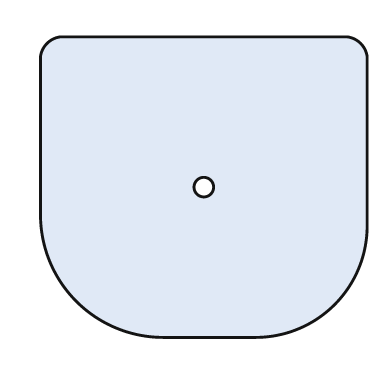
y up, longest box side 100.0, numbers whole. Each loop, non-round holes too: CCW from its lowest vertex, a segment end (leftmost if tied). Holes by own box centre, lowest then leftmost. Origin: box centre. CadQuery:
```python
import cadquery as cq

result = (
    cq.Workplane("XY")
    .moveTo(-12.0, -46.0)
    .lineTo(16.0, -46.0)
    .threePointArc((40.0, -36.0), (50.0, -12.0))
    .lineTo(50.0, 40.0)
    .threePointArc((48.0, 44.0), (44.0, 46.0))
    .lineTo(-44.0, 46.0)
    .threePointArc((-48.0, 44.0), (-50.0, 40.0))
    .lineTo(-50.0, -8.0)
    .threePointArc((-39.0, -35.0), (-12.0, -46.0))
    .close()
    .moveTo(0.0, 0.0)
    .circle(3.0)
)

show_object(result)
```